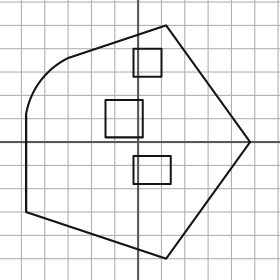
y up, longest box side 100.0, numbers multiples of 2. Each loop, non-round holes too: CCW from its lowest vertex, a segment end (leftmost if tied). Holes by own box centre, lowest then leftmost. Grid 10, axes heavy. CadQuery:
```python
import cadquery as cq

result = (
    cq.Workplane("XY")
    .moveTo(12.0, -50.0)
    .lineTo(48.0, 0.0)
    .lineTo(12.0, 50.0)
    .lineTo(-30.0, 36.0)
    .threePointArc((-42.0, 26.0), (-48.0, 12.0))
    .lineTo(-48.0, -30.0)
    .close()
    .moveTo(-2.0, -18.0)
    .lineTo(14.0, -18.0)
    .lineTo(14.0, -6.0)
    .lineTo(-2.0, -6.0)
    .close()
    .moveTo(-14.0, 2.0)
    .lineTo(2.0, 2.0)
    .lineTo(2.0, 18.0)
    .lineTo(-14.0, 18.0)
    .close()
    .moveTo(-2.0, 28.0)
    .lineTo(10.0, 28.0)
    .lineTo(10.0, 40.0)
    .lineTo(-2.0, 40.0)
    .close()
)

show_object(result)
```